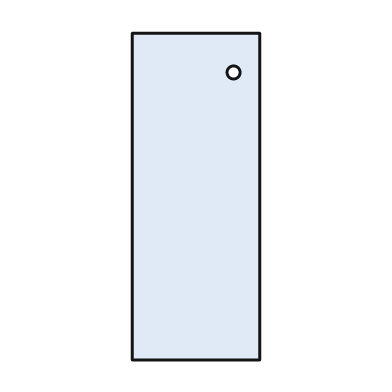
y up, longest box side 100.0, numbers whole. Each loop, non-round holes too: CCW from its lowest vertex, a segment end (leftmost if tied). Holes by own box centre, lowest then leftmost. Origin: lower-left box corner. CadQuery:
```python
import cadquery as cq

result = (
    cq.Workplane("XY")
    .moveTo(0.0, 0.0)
    .lineTo(39.0, 0.0)
    .lineTo(39.0, 100.0)
    .lineTo(0.0, 100.0)
    .close()
    .moveTo(31.0, 88.0)
    .circle(2.0)
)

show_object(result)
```